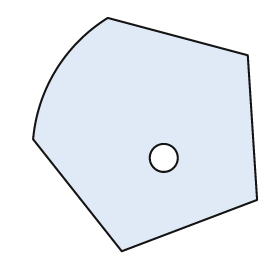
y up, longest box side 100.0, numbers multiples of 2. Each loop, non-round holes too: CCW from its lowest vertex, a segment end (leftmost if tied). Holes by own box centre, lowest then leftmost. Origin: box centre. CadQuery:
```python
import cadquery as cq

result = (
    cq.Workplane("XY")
    .moveTo(-10.0, -50.0)
    .lineTo(48.0, -28.0)
    .lineTo(44.0, 34.0)
    .lineTo(-16.0, 50.0)
    .threePointArc((-38.0, 28.0), (-48.0, -2.0))
    .close()
    .moveTo(8.0, -10.0)
    .circle(6.0)
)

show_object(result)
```